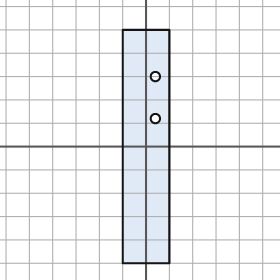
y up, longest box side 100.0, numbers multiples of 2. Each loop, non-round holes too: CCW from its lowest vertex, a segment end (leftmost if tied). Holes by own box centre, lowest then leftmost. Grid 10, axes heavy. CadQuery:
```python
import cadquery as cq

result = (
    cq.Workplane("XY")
    .moveTo(-10.0, -50.0)
    .lineTo(10.0, -50.0)
    .lineTo(10.0, 50.0)
    .lineTo(-10.0, 50.0)
    .close()
    .moveTo(4.0, 12.0)
    .circle(2.0)
    .moveTo(4.0, 30.0)
    .circle(2.0)
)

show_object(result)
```